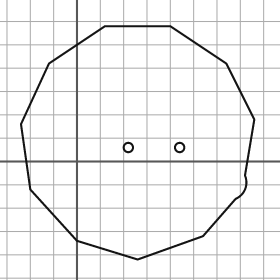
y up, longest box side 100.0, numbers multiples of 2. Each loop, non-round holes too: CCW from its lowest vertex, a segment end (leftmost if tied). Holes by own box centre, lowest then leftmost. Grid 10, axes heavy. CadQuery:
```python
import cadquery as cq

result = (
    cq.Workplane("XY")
    .moveTo(26.0, -42.0)
    .lineTo(54.0, -32.0)
    .lineTo(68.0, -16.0)
    .threePointArc((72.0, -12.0), (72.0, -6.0))
    .lineTo(76.0, 18.0)
    .lineTo(64.0, 42.0)
    .lineTo(40.0, 58.0)
    .lineTo(12.0, 58.0)
    .lineTo(-12.0, 42.0)
    .lineTo(-24.0, 16.0)
    .lineTo(-20.0, -12.0)
    .lineTo(0.0, -34.0)
    .close()
    .moveTo(22.0, 6.0)
    .circle(2.0)
    .moveTo(44.0, 6.0)
    .circle(2.0)
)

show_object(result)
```